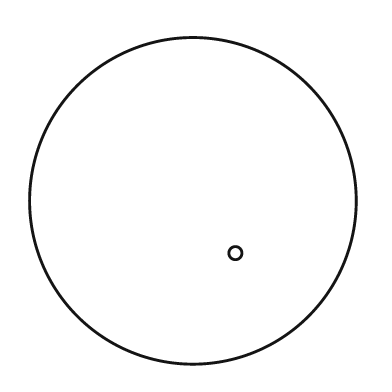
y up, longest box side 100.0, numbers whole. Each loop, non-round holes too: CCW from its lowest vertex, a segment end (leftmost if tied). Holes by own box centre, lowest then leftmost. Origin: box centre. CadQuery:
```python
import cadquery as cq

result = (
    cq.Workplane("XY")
    .moveTo(0.0, 0.0)
    .circle(50.0)
    .moveTo(13.0, -16.0)
    .circle(2.0)
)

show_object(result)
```